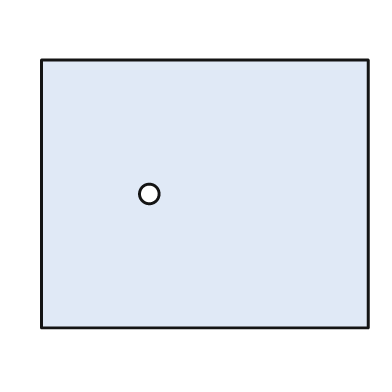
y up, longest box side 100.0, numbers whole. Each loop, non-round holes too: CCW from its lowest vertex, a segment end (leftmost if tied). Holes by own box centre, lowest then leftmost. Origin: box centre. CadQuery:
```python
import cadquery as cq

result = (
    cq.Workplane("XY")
    .moveTo(-50.0, -41.0)
    .lineTo(50.0, -41.0)
    .lineTo(50.0, 41.0)
    .lineTo(-50.0, 41.0)
    .close()
    .moveTo(-17.0, 0.0)
    .circle(3.0)
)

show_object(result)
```